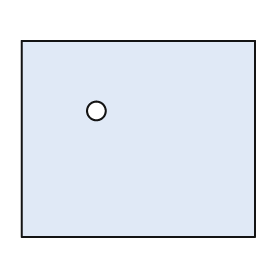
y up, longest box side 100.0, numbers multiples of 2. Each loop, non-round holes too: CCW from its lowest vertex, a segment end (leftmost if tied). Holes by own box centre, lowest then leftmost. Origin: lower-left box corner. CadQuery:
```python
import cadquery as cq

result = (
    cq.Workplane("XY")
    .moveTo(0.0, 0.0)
    .lineTo(100.0, 0.0)
    .lineTo(100.0, 84.0)
    .lineTo(0.0, 84.0)
    .close()
    .moveTo(32.0, 54.0)
    .circle(4.0)
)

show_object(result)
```